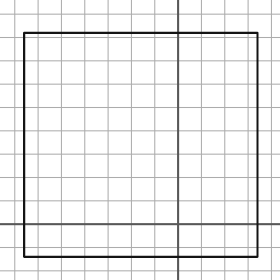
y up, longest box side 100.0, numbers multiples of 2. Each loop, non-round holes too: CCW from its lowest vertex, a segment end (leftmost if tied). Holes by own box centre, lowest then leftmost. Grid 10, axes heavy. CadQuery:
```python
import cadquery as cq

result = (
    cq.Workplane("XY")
    .moveTo(-66.0, -14.0)
    .lineTo(34.0, -14.0)
    .lineTo(34.0, 82.0)
    .lineTo(-66.0, 82.0)
    .close()
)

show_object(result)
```